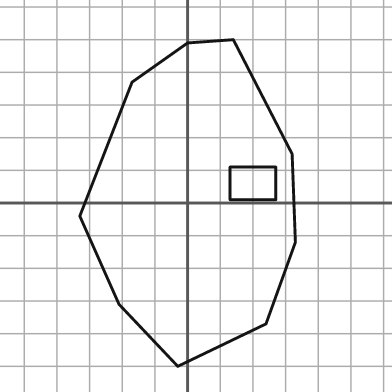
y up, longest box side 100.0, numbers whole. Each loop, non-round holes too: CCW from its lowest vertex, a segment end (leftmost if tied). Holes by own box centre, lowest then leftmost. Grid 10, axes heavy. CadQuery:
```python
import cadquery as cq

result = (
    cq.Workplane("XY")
    .moveTo(-3.0, -50.0)
    .lineTo(24.0, -37.0)
    .lineTo(33.0, -12.0)
    .lineTo(32.0, 15.0)
    .lineTo(14.0, 50.0)
    .lineTo(0.0, 49.0)
    .lineTo(-17.0, 37.0)
    .lineTo(-33.0, -4.0)
    .lineTo(-21.0, -31.0)
    .close()
    .moveTo(13.0, 1.0)
    .lineTo(27.0, 1.0)
    .lineTo(27.0, 11.0)
    .lineTo(13.0, 11.0)
    .close()
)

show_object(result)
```